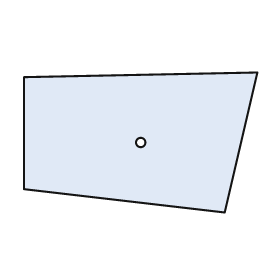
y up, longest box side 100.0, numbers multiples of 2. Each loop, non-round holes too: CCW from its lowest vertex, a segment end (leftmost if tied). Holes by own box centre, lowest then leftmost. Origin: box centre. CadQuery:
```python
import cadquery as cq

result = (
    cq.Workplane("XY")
    .moveTo(36.0, -30.0)
    .lineTo(50.0, 30.0)
    .lineTo(-50.0, 28.0)
    .lineTo(-50.0, -20.0)
    .close()
    .moveTo(0.0, 0.0)
    .circle(2.0)
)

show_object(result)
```